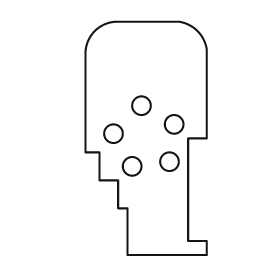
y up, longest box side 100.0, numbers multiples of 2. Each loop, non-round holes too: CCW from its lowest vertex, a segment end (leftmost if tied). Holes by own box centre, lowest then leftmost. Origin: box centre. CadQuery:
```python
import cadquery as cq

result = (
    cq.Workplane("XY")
    .moveTo(-8.0, -50.0)
    .lineTo(26.0, -50.0)
    .lineTo(26.0, -44.0)
    .lineTo(18.0, -44.0)
    .lineTo(18.0, 0.0)
    .lineTo(26.0, 0.0)
    .lineTo(26.0, 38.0)
    .threePointArc((22.0, 46.0), (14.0, 50.0))
    .lineTo(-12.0, 50.0)
    .threePointArc((-22.0, 46.0), (-26.0, 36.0))
    .lineTo(-26.0, -6.0)
    .lineTo(-20.0, -6.0)
    .lineTo(-20.0, -18.0)
    .lineTo(-12.0, -18.0)
    .lineTo(-12.0, -30.0)
    .lineTo(-8.0, -30.0)
    .close()
    .moveTo(-6.0, -12.0)
    .circle(4.0)
    .moveTo(10.0, -10.0)
    .circle(4.0)
    .moveTo(-14.0, 2.0)
    .circle(4.0)
    .moveTo(12.0, 6.0)
    .circle(4.0)
    .moveTo(-2.0, 14.0)
    .circle(4.0)
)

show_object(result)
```